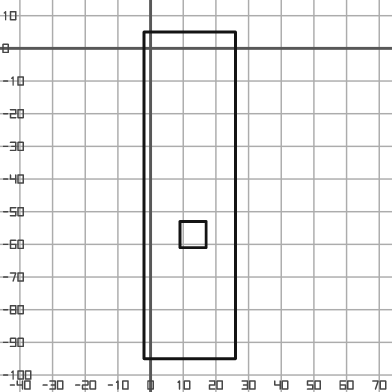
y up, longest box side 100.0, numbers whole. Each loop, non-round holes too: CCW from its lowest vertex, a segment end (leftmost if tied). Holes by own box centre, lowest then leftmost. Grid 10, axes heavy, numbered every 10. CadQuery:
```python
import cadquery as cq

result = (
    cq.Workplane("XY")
    .moveTo(-2.0, -95.0)
    .lineTo(26.0, -95.0)
    .lineTo(26.0, 5.0)
    .lineTo(-2.0, 5.0)
    .close()
    .moveTo(9.0, -61.0)
    .lineTo(17.0, -61.0)
    .lineTo(17.0, -53.0)
    .lineTo(9.0, -53.0)
    .close()
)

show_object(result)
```